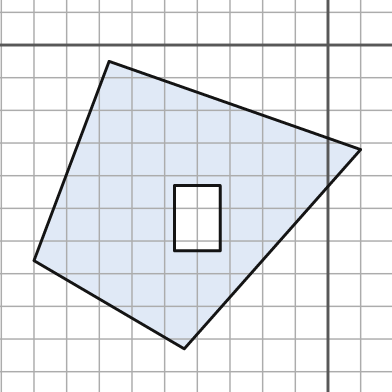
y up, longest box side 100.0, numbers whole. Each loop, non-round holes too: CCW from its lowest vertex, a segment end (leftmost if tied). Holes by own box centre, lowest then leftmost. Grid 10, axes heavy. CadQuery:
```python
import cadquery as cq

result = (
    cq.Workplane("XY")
    .moveTo(-44.0, -93.0)
    .lineTo(10.0, -32.0)
    .lineTo(-67.0, -5.0)
    .lineTo(-90.0, -66.0)
    .close()
    .moveTo(-47.0, -63.0)
    .lineTo(-33.0, -63.0)
    .lineTo(-33.0, -43.0)
    .lineTo(-47.0, -43.0)
    .close()
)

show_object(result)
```